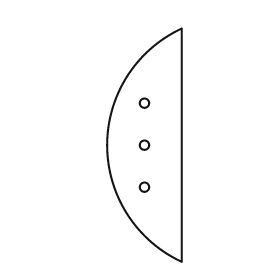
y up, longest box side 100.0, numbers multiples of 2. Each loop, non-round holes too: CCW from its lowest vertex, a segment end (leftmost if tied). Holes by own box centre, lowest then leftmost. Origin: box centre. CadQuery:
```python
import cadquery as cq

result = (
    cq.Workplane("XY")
    .moveTo(16.0, -50.0)
    .lineTo(16.0, 50.0)
    .threePointArc((-16.0, 0.0), (16.0, -50.0))
    .close()
    .moveTo(0.0, -18.0)
    .circle(2.0)
    .moveTo(0.0, 0.0)
    .circle(2.0)
    .moveTo(0.0, 18.0)
    .circle(2.0)
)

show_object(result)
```